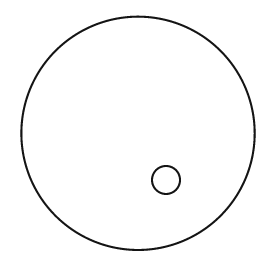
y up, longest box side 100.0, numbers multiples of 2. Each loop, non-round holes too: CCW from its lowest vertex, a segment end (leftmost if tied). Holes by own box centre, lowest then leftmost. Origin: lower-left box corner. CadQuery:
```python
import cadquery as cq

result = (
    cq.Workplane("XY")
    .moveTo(50.0, 50.0)
    .circle(50.0)
    .moveTo(62.0, 30.0)
    .circle(6.0)
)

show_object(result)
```